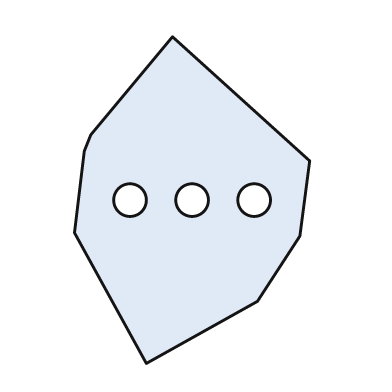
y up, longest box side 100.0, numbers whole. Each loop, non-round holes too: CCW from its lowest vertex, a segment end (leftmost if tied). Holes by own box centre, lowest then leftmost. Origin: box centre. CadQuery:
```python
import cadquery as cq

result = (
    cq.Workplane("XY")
    .moveTo(-14.0, -50.0)
    .lineTo(20.0, -31.0)
    .lineTo(33.0, -11.0)
    .lineTo(36.0, 12.0)
    .lineTo(-6.0, 50.0)
    .lineTo(-31.0, 20.0)
    .lineTo(-33.0, 15.0)
    .lineTo(-36.0, -10.0)
    .close()
    .moveTo(-19.0, 0.0)
    .circle(5.0)
    .moveTo(0.0, 0.0)
    .circle(5.0)
    .moveTo(19.0, 0.0)
    .circle(5.0)
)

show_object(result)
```